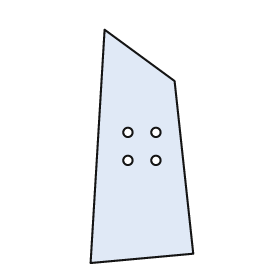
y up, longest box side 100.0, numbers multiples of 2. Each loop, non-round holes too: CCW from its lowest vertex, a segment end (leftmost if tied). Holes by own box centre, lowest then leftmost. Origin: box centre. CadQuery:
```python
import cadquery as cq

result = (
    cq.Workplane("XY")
    .moveTo(-22.0, -50.0)
    .lineTo(22.0, -46.0)
    .lineTo(14.0, 28.0)
    .lineTo(-16.0, 50.0)
    .close()
    .moveTo(-6.0, -6.0)
    .circle(2.0)
    .moveTo(6.0, -6.0)
    .circle(2.0)
    .moveTo(-6.0, 6.0)
    .circle(2.0)
    .moveTo(6.0, 6.0)
    .circle(2.0)
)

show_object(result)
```